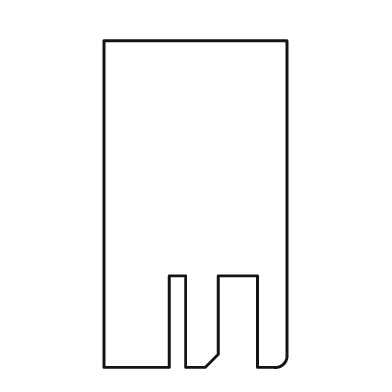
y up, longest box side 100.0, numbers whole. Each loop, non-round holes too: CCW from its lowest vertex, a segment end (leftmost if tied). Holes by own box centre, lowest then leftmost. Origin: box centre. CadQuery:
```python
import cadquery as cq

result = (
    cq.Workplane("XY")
    .moveTo(-28.0, -50.0)
    .lineTo(-8.0, -50.0)
    .lineTo(-8.0, -22.0)
    .lineTo(-3.0, -22.0)
    .lineTo(-3.0, -50.0)
    .lineTo(3.0, -50.0)
    .lineTo(7.0, -46.0)
    .lineTo(7.0, -22.0)
    .lineTo(19.0, -22.0)
    .lineTo(19.0, -50.0)
    .lineTo(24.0, -50.0)
    .threePointArc((27.0, -49.0), (28.0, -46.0))
    .lineTo(28.0, 50.0)
    .lineTo(-28.0, 50.0)
    .close()
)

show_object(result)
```